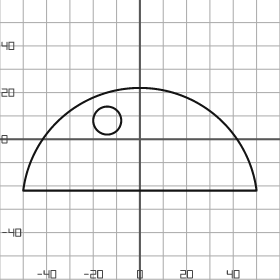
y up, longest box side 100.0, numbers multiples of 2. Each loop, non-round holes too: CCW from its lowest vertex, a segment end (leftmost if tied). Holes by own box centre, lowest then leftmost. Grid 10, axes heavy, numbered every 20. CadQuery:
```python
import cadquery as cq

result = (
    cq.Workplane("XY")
    .moveTo(-50.0, -22.0)
    .lineTo(50.0, -22.0)
    .threePointArc((0.0, 22.0), (-50.0, -22.0))
    .close()
    .moveTo(-14.0, 8.0)
    .circle(6.0)
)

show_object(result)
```